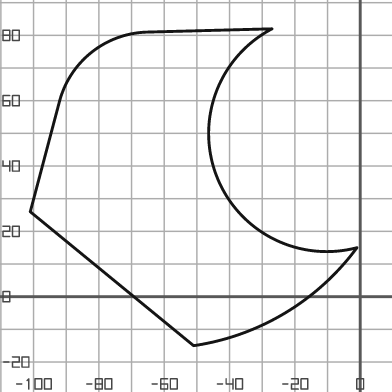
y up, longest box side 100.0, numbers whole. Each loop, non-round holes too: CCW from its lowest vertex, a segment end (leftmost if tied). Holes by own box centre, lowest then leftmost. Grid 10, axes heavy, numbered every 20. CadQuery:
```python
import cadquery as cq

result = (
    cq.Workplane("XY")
    .moveTo(-51.0, -15.0)
    .threePointArc((-23.0, -5.0), (-1.0, 15.0))
    .threePointArc((-44.0, 37.0), (-27.0, 82.0))
    .lineTo(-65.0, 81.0)
    .threePointArc((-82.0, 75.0), (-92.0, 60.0))
    .lineTo(-101.0, 26.0)
    .close()
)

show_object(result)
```